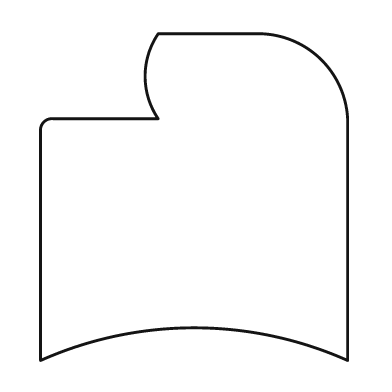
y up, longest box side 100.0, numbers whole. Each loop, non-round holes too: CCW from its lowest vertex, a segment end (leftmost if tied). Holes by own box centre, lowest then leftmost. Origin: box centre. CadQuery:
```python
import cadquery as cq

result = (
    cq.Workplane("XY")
    .moveTo(-47.0, -50.0)
    .threePointArc((0.0, -40.0), (47.0, -50.0))
    .lineTo(47.0, 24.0)
    .threePointArc((39.0, 42.0), (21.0, 50.0))
    .lineTo(-11.0, 50.0)
    .threePointArc((-15.0, 37.0), (-11.0, 24.0))
    .lineTo(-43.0, 24.0)
    .threePointArc((-46.0, 23.0), (-47.0, 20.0))
    .close()
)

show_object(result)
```